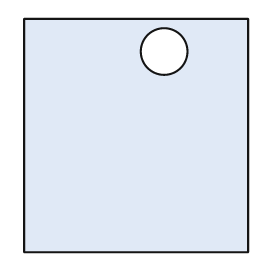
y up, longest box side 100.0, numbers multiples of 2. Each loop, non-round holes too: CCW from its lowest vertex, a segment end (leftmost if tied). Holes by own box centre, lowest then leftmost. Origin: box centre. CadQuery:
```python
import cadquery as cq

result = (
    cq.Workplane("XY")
    .moveTo(-48.0, -50.0)
    .lineTo(48.0, -50.0)
    .lineTo(48.0, 50.0)
    .lineTo(-48.0, 50.0)
    .close()
    .moveTo(12.0, 36.0)
    .circle(10.0)
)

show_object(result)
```